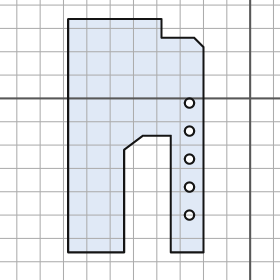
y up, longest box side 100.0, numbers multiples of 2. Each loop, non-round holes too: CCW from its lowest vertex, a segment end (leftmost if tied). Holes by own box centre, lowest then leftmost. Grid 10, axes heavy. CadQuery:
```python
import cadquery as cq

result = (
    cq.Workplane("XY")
    .moveTo(-78.0, -66.0)
    .lineTo(-54.0, -66.0)
    .lineTo(-54.0, -22.0)
    .lineTo(-46.0, -16.0)
    .lineTo(-34.0, -16.0)
    .lineTo(-34.0, -66.0)
    .lineTo(-20.0, -66.0)
    .lineTo(-20.0, 22.0)
    .lineTo(-24.0, 26.0)
    .lineTo(-38.0, 26.0)
    .lineTo(-38.0, 34.0)
    .lineTo(-78.0, 34.0)
    .close()
    .moveTo(-26.0, -50.0)
    .circle(2.0)
    .moveTo(-26.0, -38.0)
    .circle(2.0)
    .moveTo(-26.0, -26.0)
    .circle(2.0)
    .moveTo(-26.0, -14.0)
    .circle(2.0)
    .moveTo(-26.0, -2.0)
    .circle(2.0)
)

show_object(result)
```